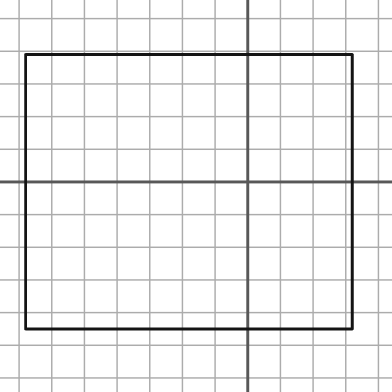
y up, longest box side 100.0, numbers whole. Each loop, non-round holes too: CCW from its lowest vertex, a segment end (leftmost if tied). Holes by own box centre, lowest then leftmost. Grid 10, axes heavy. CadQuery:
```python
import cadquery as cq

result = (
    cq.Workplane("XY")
    .moveTo(-68.0, -45.0)
    .lineTo(32.0, -45.0)
    .lineTo(32.0, 39.0)
    .lineTo(-68.0, 39.0)
    .close()
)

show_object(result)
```